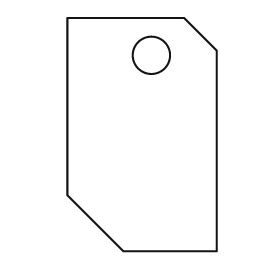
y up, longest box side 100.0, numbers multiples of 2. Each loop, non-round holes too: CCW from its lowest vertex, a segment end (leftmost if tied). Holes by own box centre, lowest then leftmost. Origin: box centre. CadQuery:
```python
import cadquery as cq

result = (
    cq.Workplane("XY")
    .moveTo(-8.0, -50.0)
    .lineTo(32.0, -50.0)
    .lineTo(32.0, 36.0)
    .lineTo(18.0, 50.0)
    .lineTo(-32.0, 50.0)
    .lineTo(-32.0, -26.0)
    .close()
    .moveTo(4.0, 34.0)
    .circle(8.0)
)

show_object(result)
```